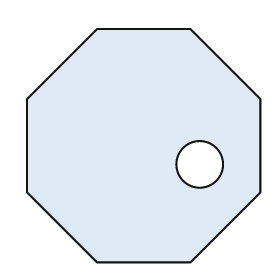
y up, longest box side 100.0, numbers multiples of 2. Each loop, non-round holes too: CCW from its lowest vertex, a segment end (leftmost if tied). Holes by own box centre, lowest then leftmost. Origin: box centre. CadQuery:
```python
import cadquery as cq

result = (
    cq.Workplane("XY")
    .moveTo(-20.0, -50.0)
    .lineTo(20.0, -50.0)
    .lineTo(50.0, -20.0)
    .lineTo(50.0, 20.0)
    .lineTo(20.0, 50.0)
    .lineTo(-20.0, 50.0)
    .lineTo(-50.0, 20.0)
    .lineTo(-50.0, -20.0)
    .close()
    .moveTo(24.0, -8.0)
    .circle(10.0)
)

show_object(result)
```